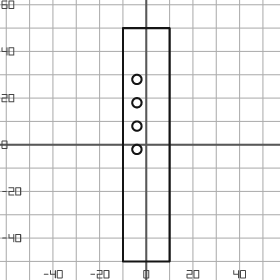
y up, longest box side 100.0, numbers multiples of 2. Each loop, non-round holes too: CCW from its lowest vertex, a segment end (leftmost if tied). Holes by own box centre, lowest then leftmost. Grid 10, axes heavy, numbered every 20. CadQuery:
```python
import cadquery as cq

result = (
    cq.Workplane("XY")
    .moveTo(-10.0, -50.0)
    .lineTo(10.0, -50.0)
    .lineTo(10.0, 50.0)
    .lineTo(-10.0, 50.0)
    .close()
    .moveTo(-4.0, -2.0)
    .circle(2.0)
    .moveTo(-4.0, 8.0)
    .circle(2.0)
    .moveTo(-4.0, 18.0)
    .circle(2.0)
    .moveTo(-4.0, 28.0)
    .circle(2.0)
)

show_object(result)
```